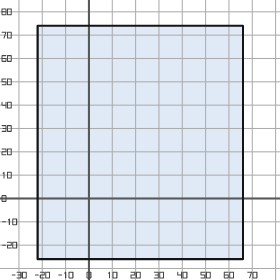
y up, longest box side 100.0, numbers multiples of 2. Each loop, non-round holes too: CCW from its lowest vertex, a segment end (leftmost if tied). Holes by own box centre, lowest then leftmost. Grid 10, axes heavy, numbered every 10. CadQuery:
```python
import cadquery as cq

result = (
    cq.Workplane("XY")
    .moveTo(-22.0, -26.0)
    .lineTo(66.0, -26.0)
    .lineTo(66.0, 74.0)
    .lineTo(-22.0, 74.0)
    .close()
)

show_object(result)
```